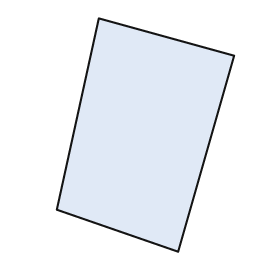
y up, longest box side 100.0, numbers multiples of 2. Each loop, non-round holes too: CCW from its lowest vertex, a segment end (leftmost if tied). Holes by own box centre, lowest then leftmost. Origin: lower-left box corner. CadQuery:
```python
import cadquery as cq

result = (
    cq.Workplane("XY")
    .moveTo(52.0, 0.0)
    .lineTo(76.0, 84.0)
    .lineTo(18.0, 100.0)
    .lineTo(0.0, 18.0)
    .close()
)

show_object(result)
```